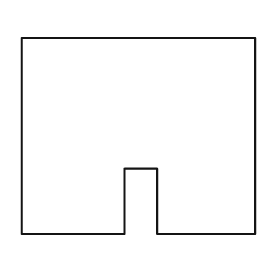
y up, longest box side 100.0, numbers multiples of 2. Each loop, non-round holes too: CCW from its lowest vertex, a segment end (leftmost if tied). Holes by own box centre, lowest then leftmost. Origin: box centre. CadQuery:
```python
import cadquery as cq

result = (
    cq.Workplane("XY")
    .moveTo(-50.0, -42.0)
    .lineTo(-6.0, -42.0)
    .lineTo(-6.0, -14.0)
    .lineTo(8.0, -14.0)
    .lineTo(8.0, -42.0)
    .lineTo(50.0, -42.0)
    .lineTo(50.0, 42.0)
    .lineTo(-50.0, 42.0)
    .close()
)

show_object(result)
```